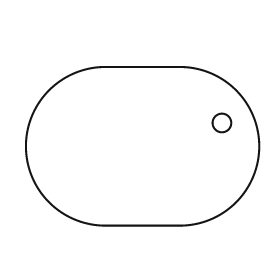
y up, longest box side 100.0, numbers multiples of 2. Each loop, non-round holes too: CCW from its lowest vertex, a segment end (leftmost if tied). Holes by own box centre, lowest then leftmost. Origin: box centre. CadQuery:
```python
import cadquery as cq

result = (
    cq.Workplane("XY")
    .moveTo(-16.0, -34.0)
    .lineTo(16.0, -34.0)
    .threePointArc((50.0, 0.0), (16.0, 34.0))
    .lineTo(-16.0, 34.0)
    .threePointArc((-50.0, 0.0), (-16.0, -34.0))
    .close()
    .moveTo(34.0, 10.0)
    .circle(4.0)
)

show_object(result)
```